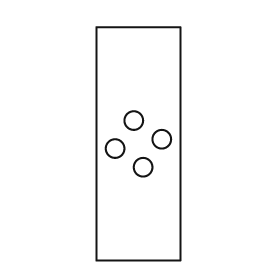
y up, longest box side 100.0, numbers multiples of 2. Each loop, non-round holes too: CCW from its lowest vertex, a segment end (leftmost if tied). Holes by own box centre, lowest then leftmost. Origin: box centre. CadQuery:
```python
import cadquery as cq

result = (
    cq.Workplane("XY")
    .moveTo(-18.0, -50.0)
    .lineTo(18.0, -50.0)
    .lineTo(18.0, 50.0)
    .lineTo(-18.0, 50.0)
    .close()
    .moveTo(2.0, -10.0)
    .circle(4.0)
    .moveTo(-10.0, -2.0)
    .circle(4.0)
    .moveTo(10.0, 2.0)
    .circle(4.0)
    .moveTo(-2.0, 10.0)
    .circle(4.0)
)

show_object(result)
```